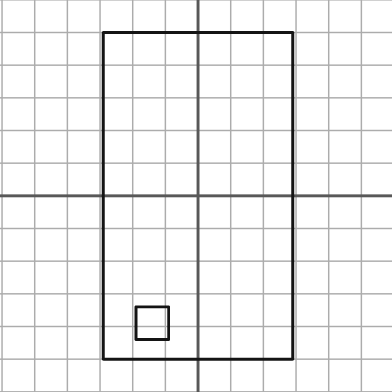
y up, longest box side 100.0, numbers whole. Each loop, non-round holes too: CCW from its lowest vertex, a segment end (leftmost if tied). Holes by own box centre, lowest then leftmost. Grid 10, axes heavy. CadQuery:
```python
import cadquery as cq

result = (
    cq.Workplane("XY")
    .moveTo(-29.0, -50.0)
    .lineTo(29.0, -50.0)
    .lineTo(29.0, 50.0)
    .lineTo(-29.0, 50.0)
    .close()
    .moveTo(-19.0, -44.0)
    .lineTo(-9.0, -44.0)
    .lineTo(-9.0, -34.0)
    .lineTo(-19.0, -34.0)
    .close()
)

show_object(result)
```